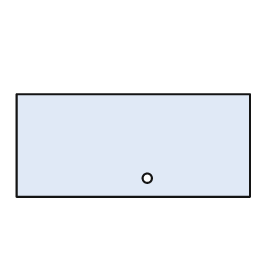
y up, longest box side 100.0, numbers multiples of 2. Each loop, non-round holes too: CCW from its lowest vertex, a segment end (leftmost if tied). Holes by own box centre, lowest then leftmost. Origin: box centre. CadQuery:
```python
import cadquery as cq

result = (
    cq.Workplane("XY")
    .moveTo(-50.0, -22.0)
    .lineTo(50.0, -22.0)
    .lineTo(50.0, 22.0)
    .lineTo(-50.0, 22.0)
    .close()
    .moveTo(6.0, -14.0)
    .circle(2.0)
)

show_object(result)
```